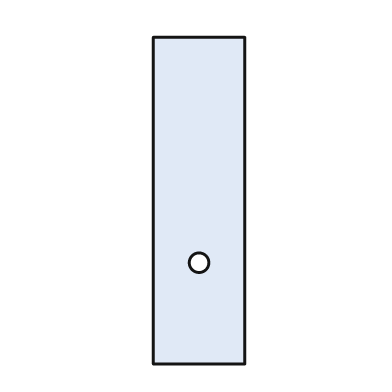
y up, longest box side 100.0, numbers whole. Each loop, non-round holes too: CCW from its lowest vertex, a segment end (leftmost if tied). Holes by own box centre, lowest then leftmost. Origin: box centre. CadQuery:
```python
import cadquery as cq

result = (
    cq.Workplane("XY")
    .moveTo(-14.0, -50.0)
    .lineTo(14.0, -50.0)
    .lineTo(14.0, 50.0)
    .lineTo(-14.0, 50.0)
    .close()
    .moveTo(0.0, -19.0)
    .circle(3.0)
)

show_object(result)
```